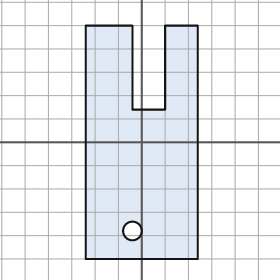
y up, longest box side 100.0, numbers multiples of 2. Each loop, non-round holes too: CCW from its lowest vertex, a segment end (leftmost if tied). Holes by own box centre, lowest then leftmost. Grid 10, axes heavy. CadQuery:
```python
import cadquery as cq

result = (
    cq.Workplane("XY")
    .moveTo(-24.0, -50.0)
    .lineTo(24.0, -50.0)
    .lineTo(24.0, 50.0)
    .lineTo(10.0, 50.0)
    .lineTo(10.0, 14.0)
    .lineTo(-4.0, 14.0)
    .lineTo(-4.0, 50.0)
    .lineTo(-24.0, 50.0)
    .close()
    .moveTo(-4.0, -38.0)
    .circle(4.0)
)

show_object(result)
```